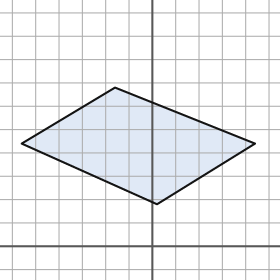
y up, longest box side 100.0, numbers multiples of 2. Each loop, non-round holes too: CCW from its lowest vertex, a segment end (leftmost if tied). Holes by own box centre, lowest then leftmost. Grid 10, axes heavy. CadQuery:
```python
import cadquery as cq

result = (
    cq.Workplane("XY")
    .moveTo(2.0, 18.0)
    .lineTo(44.0, 44.0)
    .lineTo(-16.0, 68.0)
    .lineTo(-56.0, 44.0)
    .close()
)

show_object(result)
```